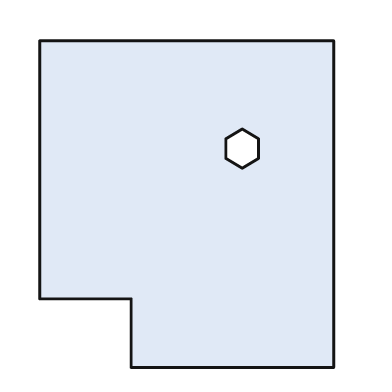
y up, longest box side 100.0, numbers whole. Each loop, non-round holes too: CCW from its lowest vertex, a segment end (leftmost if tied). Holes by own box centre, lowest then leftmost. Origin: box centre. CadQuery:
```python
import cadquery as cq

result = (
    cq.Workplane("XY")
    .moveTo(-17.0, -50.0)
    .lineTo(45.0, -50.0)
    .lineTo(45.0, 50.0)
    .lineTo(-45.0, 50.0)
    .lineTo(-45.0, -29.0)
    .lineTo(-17.0, -29.0)
    .close()
    .moveTo(17.0, 11.0)
    .lineTo(22.0, 14.0)
    .lineTo(22.0, 20.0)
    .lineTo(17.0, 23.0)
    .lineTo(12.0, 20.0)
    .lineTo(12.0, 14.0)
    .close()
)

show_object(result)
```